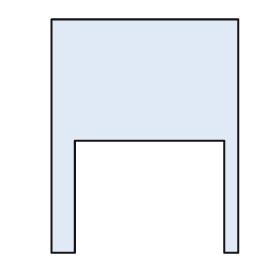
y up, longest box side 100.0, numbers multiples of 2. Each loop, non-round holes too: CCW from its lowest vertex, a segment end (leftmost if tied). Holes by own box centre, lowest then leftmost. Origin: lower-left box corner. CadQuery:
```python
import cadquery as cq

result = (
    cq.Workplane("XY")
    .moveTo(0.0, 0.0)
    .lineTo(10.0, 0.0)
    .lineTo(10.0, 48.0)
    .lineTo(74.0, 48.0)
    .lineTo(74.0, 0.0)
    .lineTo(80.0, 0.0)
    .lineTo(80.0, 100.0)
    .lineTo(0.0, 100.0)
    .close()
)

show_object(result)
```